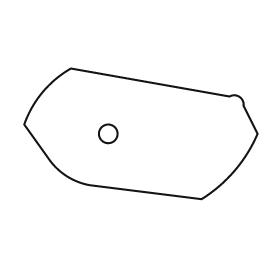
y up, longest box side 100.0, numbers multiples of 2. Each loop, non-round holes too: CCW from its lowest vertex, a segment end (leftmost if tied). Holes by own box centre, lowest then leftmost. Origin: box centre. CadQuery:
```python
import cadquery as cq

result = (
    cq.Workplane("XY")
    .moveTo(26.0, -28.0)
    .threePointArc((40.0, -16.0), (50.0, 0.0))
    .lineTo(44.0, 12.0)
    .threePointArc((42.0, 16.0), (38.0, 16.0))
    .lineTo(-30.0, 28.0)
    .threePointArc((-42.0, 18.0), (-50.0, 4.0))
    .lineTo(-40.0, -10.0)
    .threePointArc((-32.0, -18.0), (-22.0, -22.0))
    .close()
    .moveTo(-14.0, 0.0)
    .circle(4.0)
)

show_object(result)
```